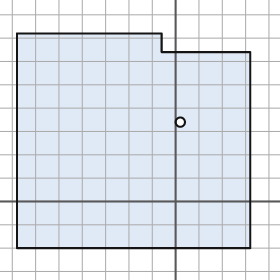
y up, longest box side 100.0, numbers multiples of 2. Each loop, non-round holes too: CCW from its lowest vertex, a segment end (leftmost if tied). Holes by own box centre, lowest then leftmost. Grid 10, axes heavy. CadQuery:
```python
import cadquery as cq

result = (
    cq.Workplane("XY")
    .moveTo(-68.0, -20.0)
    .lineTo(32.0, -20.0)
    .lineTo(32.0, 64.0)
    .lineTo(-6.0, 64.0)
    .lineTo(-6.0, 72.0)
    .lineTo(-68.0, 72.0)
    .close()
    .moveTo(2.0, 34.0)
    .circle(2.0)
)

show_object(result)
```